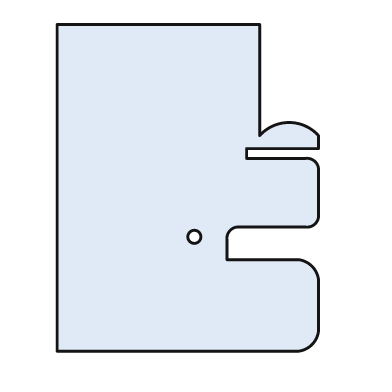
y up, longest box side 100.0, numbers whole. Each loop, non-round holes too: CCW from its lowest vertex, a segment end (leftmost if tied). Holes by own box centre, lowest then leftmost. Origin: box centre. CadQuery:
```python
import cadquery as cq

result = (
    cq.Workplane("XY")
    .moveTo(-40.0, -50.0)
    .lineTo(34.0, -50.0)
    .threePointArc((38.0, -48.0), (40.0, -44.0))
    .lineTo(40.0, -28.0)
    .threePointArc((38.0, -24.0), (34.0, -22.0))
    .lineTo(12.0, -22.0)
    .lineTo(12.0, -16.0)
    .threePointArc((13.0, -13.0), (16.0, -12.0))
    .lineTo(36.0, -12.0)
    .threePointArc((39.0, -11.0), (40.0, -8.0))
    .lineTo(40.0, 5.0)
    .threePointArc((39.0, 8.0), (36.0, 9.0))
    .lineTo(18.0, 9.0)
    .lineTo(18.0, 12.0)
    .lineTo(40.0, 12.0)
    .lineTo(40.0, 16.0)
    .threePointArc((31.0, 20.0), (22.0, 16.0))
    .lineTo(22.0, 50.0)
    .lineTo(-40.0, 50.0)
    .close()
    .moveTo(2.0, -15.0)
    .circle(2.0)
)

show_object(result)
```